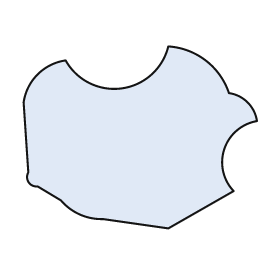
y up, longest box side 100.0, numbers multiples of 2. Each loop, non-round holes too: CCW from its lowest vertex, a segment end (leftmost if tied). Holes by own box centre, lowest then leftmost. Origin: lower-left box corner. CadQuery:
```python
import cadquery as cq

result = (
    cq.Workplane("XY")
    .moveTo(62.0, 0.0)
    .lineTo(90.0, 16.0)
    .threePointArc((86.0, 34.0), (100.0, 46.0))
    .threePointArc((96.0, 54.0), (88.0, 58.0))
    .threePointArc((78.0, 72.0), (62.0, 78.0))
    .threePointArc((42.0, 60.0), (18.0, 72.0))
    .threePointArc((6.0, 66.0), (0.0, 54.0))
    .lineTo(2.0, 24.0)
    .threePointArc((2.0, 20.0), (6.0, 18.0))
    .lineTo(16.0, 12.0)
    .threePointArc((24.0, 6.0), (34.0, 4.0))
    .close()
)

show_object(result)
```